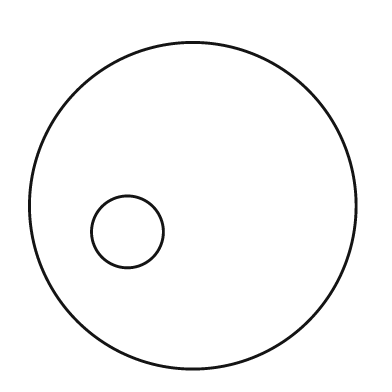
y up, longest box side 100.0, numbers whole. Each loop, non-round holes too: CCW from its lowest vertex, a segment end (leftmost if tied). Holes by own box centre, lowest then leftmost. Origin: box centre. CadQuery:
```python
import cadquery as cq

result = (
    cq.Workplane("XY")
    .moveTo(0.0, 0.0)
    .circle(50.0)
    .moveTo(-20.0, -8.0)
    .circle(11.0)
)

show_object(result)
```